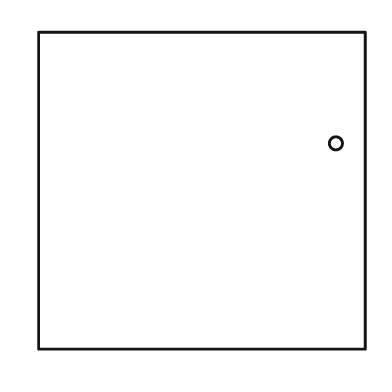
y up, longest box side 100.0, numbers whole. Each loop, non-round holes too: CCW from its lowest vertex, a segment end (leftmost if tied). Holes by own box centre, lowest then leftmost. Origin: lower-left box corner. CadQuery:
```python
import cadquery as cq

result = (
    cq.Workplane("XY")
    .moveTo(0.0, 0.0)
    .lineTo(100.0, 0.0)
    .lineTo(100.0, 97.0)
    .lineTo(0.0, 97.0)
    .close()
    .moveTo(91.0, 63.0)
    .circle(2.0)
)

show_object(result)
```